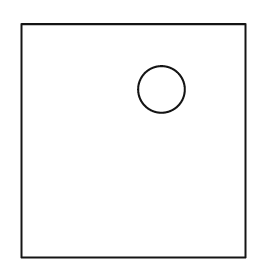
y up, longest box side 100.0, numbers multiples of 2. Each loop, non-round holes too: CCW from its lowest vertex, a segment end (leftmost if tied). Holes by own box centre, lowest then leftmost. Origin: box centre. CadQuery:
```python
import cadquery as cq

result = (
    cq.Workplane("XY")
    .moveTo(-48.0, -50.0)
    .lineTo(48.0, -50.0)
    .lineTo(48.0, 50.0)
    .lineTo(-48.0, 50.0)
    .close()
    .moveTo(12.0, 22.0)
    .circle(10.0)
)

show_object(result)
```